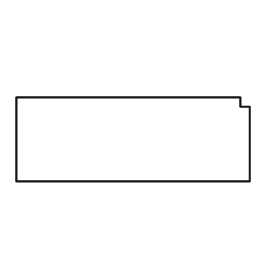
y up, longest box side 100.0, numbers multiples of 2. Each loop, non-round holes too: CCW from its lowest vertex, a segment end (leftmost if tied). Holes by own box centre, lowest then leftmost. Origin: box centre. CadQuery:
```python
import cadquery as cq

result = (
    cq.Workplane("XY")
    .moveTo(-50.0, -18.0)
    .lineTo(50.0, -18.0)
    .lineTo(50.0, 14.0)
    .lineTo(46.0, 14.0)
    .lineTo(46.0, 18.0)
    .lineTo(-50.0, 18.0)
    .close()
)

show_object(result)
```